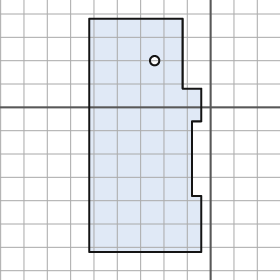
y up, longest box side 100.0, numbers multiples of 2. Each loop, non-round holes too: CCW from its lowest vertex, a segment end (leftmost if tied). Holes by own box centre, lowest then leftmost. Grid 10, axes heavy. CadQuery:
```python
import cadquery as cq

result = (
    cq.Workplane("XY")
    .moveTo(-52.0, -62.0)
    .lineTo(-4.0, -62.0)
    .lineTo(-4.0, -38.0)
    .lineTo(-8.0, -38.0)
    .lineTo(-8.0, -6.0)
    .lineTo(-4.0, -6.0)
    .lineTo(-4.0, 8.0)
    .lineTo(-12.0, 8.0)
    .lineTo(-12.0, 38.0)
    .lineTo(-52.0, 38.0)
    .close()
    .moveTo(-24.0, 20.0)
    .circle(2.0)
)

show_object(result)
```